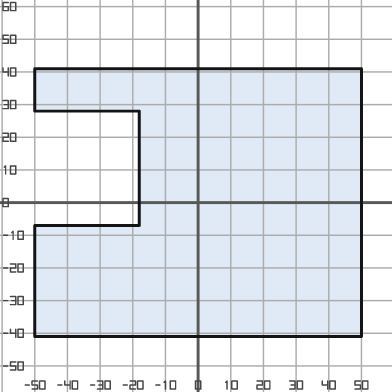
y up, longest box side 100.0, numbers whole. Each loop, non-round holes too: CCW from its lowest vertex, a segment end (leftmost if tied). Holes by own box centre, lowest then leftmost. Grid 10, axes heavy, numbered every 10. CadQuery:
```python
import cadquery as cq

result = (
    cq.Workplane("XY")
    .moveTo(-50.0, -41.0)
    .lineTo(50.0, -41.0)
    .lineTo(50.0, 41.0)
    .lineTo(-50.0, 41.0)
    .lineTo(-50.0, 28.0)
    .lineTo(-18.0, 28.0)
    .lineTo(-18.0, -7.0)
    .lineTo(-50.0, -7.0)
    .close()
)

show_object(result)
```